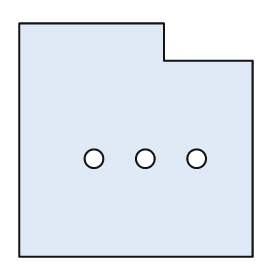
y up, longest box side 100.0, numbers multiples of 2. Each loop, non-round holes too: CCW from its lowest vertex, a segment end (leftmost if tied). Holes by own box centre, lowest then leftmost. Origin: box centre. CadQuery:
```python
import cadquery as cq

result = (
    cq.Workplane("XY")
    .moveTo(-50.0, -50.0)
    .lineTo(50.0, -50.0)
    .lineTo(50.0, 34.0)
    .lineTo(12.0, 34.0)
    .lineTo(12.0, 50.0)
    .lineTo(-50.0, 50.0)
    .close()
    .moveTo(-18.0, -8.0)
    .circle(4.0)
    .moveTo(4.0, -8.0)
    .circle(4.0)
    .moveTo(26.0, -8.0)
    .circle(4.0)
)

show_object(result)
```